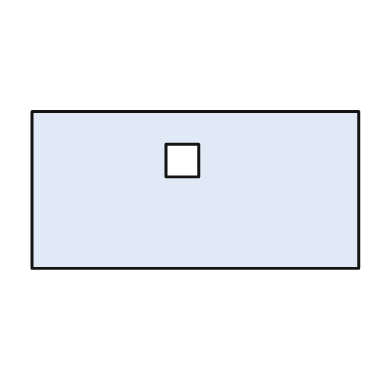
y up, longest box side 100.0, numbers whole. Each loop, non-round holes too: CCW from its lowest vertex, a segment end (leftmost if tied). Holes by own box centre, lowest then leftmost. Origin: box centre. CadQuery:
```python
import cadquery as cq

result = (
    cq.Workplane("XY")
    .moveTo(-50.0, -24.0)
    .lineTo(50.0, -24.0)
    .lineTo(50.0, 24.0)
    .lineTo(-50.0, 24.0)
    .close()
    .moveTo(-9.0, 4.0)
    .lineTo(1.0, 4.0)
    .lineTo(1.0, 14.0)
    .lineTo(-9.0, 14.0)
    .close()
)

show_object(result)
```